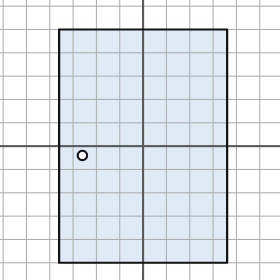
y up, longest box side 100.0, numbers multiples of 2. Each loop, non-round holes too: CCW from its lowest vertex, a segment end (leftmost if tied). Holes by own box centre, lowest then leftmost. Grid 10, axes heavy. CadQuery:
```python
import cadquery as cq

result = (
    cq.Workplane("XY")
    .moveTo(-36.0, -50.0)
    .lineTo(36.0, -50.0)
    .lineTo(36.0, 50.0)
    .lineTo(-36.0, 50.0)
    .close()
    .moveTo(-26.0, -4.0)
    .circle(2.0)
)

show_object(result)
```